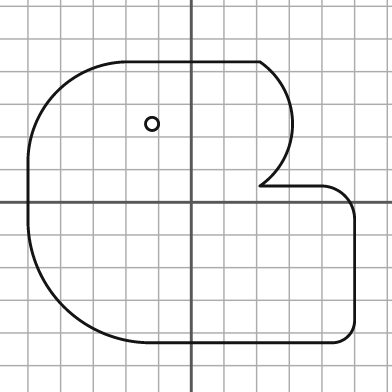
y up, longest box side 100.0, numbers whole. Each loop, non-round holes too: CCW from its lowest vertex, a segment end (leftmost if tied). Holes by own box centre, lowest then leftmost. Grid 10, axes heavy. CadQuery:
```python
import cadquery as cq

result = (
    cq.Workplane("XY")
    .moveTo(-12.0, -43.0)
    .lineTo(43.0, -43.0)
    .threePointArc((48.0, -41.0), (50.0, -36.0))
    .lineTo(50.0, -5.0)
    .threePointArc((47.0, 2.0), (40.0, 5.0))
    .lineTo(21.0, 5.0)
    .threePointArc((31.0, 24.0), (21.0, 43.0))
    .lineTo(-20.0, 43.0)
    .threePointArc((-41.0, 34.0), (-50.0, 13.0))
    .lineTo(-50.0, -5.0)
    .threePointArc((-39.0, -32.0), (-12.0, -43.0))
    .close()
    .moveTo(-12.0, 24.0)
    .circle(2.0)
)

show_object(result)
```